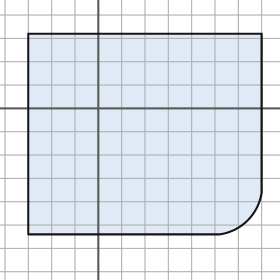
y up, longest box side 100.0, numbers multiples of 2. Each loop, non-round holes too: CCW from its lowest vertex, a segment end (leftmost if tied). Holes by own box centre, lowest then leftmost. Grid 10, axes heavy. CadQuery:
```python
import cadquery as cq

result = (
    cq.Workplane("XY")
    .moveTo(-30.0, -54.0)
    .lineTo(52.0, -54.0)
    .threePointArc((64.0, -48.0), (70.0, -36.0))
    .lineTo(70.0, 32.0)
    .lineTo(-30.0, 32.0)
    .close()
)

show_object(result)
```